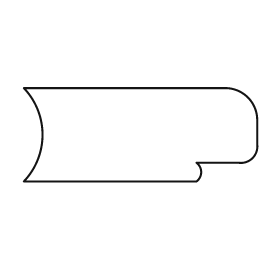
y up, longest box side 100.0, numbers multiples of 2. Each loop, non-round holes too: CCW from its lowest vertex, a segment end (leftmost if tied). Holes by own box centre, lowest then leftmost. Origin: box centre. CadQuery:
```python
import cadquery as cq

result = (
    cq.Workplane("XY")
    .moveTo(-50.0, -20.0)
    .lineTo(24.0, -20.0)
    .threePointArc((26.0, -16.0), (24.0, -12.0))
    .lineTo(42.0, -12.0)
    .threePointArc((48.0, -10.0), (50.0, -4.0))
    .lineTo(50.0, 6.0)
    .threePointArc((46.0, 16.0), (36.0, 20.0))
    .lineTo(-50.0, 20.0)
    .threePointArc((-42.0, 0.0), (-50.0, -20.0))
    .close()
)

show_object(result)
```